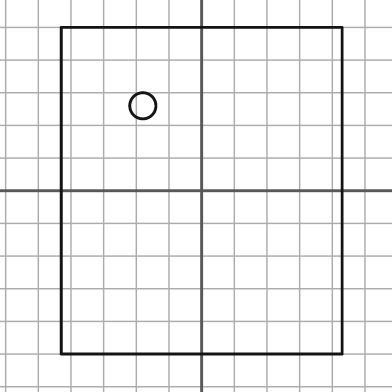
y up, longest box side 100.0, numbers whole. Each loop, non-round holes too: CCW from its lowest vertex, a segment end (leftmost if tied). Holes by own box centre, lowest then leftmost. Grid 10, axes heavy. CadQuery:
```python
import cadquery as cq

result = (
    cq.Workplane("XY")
    .moveTo(-43.0, -50.0)
    .lineTo(43.0, -50.0)
    .lineTo(43.0, 50.0)
    .lineTo(-43.0, 50.0)
    .close()
    .moveTo(-18.0, 26.0)
    .circle(4.0)
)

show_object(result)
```